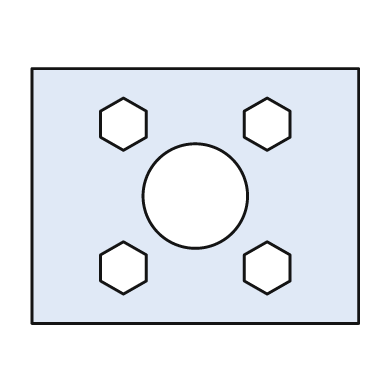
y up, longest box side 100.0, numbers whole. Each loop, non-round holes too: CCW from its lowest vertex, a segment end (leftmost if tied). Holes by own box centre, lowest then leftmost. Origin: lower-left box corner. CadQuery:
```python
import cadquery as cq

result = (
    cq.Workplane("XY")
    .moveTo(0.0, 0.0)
    .lineTo(100.0, 0.0)
    .lineTo(100.0, 78.0)
    .lineTo(0.0, 78.0)
    .close()
    .moveTo(28.0, 9.0)
    .lineTo(35.0, 13.0)
    .lineTo(35.0, 21.0)
    .lineTo(28.0, 25.0)
    .lineTo(21.0, 21.0)
    .lineTo(21.0, 13.0)
    .close()
    .moveTo(72.0, 9.0)
    .lineTo(79.0, 13.0)
    .lineTo(79.0, 21.0)
    .lineTo(72.0, 25.0)
    .lineTo(65.0, 21.0)
    .lineTo(65.0, 13.0)
    .close()
    .moveTo(50.0, 39.0)
    .circle(16.0)
    .moveTo(28.0, 53.0)
    .lineTo(35.0, 57.0)
    .lineTo(35.0, 65.0)
    .lineTo(28.0, 69.0)
    .lineTo(21.0, 65.0)
    .lineTo(21.0, 57.0)
    .close()
    .moveTo(72.0, 53.0)
    .lineTo(79.0, 57.0)
    .lineTo(79.0, 65.0)
    .lineTo(72.0, 69.0)
    .lineTo(65.0, 65.0)
    .lineTo(65.0, 57.0)
    .close()
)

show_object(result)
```